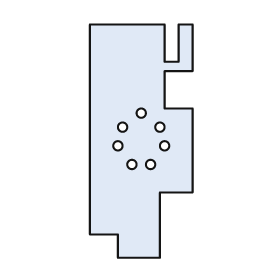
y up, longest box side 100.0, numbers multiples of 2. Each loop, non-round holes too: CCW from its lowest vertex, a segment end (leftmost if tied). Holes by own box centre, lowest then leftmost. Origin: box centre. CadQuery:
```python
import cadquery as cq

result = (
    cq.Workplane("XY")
    .moveTo(-10.0, -50.0)
    .lineTo(8.0, -50.0)
    .lineTo(8.0, -22.0)
    .lineTo(22.0, -22.0)
    .lineTo(22.0, 14.0)
    .lineTo(10.0, 14.0)
    .lineTo(10.0, 30.0)
    .lineTo(22.0, 30.0)
    .lineTo(22.0, 50.0)
    .lineTo(16.0, 50.0)
    .lineTo(16.0, 34.0)
    .lineTo(10.0, 34.0)
    .lineTo(10.0, 50.0)
    .lineTo(-22.0, 50.0)
    .lineTo(-22.0, -40.0)
    .lineTo(-10.0, -40.0)
    .close()
    .moveTo(-4.0, -10.0)
    .circle(2.0)
    .moveTo(4.0, -10.0)
    .circle(2.0)
    .moveTo(-10.0, -2.0)
    .circle(2.0)
    .moveTo(10.0, -2.0)
    .circle(2.0)
    .moveTo(-8.0, 6.0)
    .circle(2.0)
    .moveTo(8.0, 6.0)
    .circle(2.0)
    .moveTo(0.0, 12.0)
    .circle(2.0)
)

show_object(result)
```